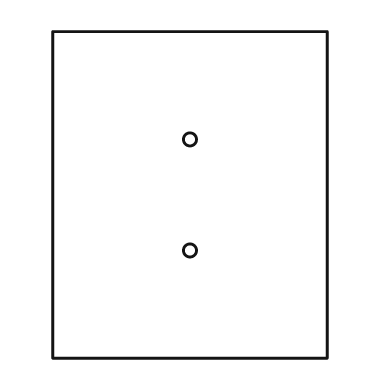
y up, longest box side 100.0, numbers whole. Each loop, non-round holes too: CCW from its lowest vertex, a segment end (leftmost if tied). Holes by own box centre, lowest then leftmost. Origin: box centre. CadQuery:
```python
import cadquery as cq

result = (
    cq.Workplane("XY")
    .moveTo(-42.0, -50.0)
    .lineTo(42.0, -50.0)
    .lineTo(42.0, 50.0)
    .lineTo(-42.0, 50.0)
    .close()
    .moveTo(0.0, -17.0)
    .circle(2.0)
    .moveTo(0.0, 17.0)
    .circle(2.0)
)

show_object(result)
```